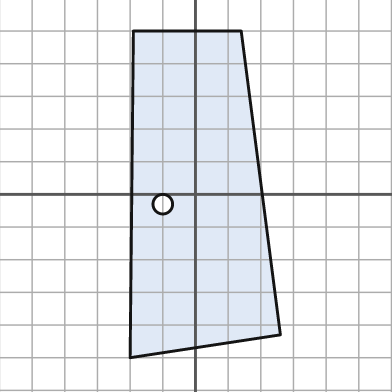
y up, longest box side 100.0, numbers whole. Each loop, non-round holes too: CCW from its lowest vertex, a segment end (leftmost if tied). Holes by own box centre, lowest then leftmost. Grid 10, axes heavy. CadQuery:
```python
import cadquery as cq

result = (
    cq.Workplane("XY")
    .moveTo(-20.0, -50.0)
    .lineTo(26.0, -43.0)
    .lineTo(14.0, 50.0)
    .lineTo(-19.0, 50.0)
    .close()
    .moveTo(-10.0, -3.0)
    .circle(3.0)
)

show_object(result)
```